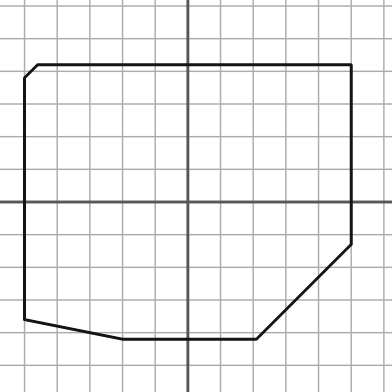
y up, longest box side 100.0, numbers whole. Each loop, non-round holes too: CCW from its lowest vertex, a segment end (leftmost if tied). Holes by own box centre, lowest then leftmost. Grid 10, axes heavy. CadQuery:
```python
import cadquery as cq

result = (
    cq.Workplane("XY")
    .moveTo(-20.0, -42.0)
    .lineTo(21.0, -42.0)
    .lineTo(50.0, -13.0)
    .lineTo(50.0, 42.0)
    .lineTo(-46.0, 42.0)
    .lineTo(-50.0, 38.0)
    .lineTo(-50.0, -36.0)
    .close()
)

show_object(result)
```